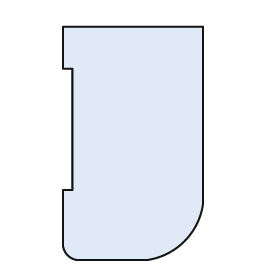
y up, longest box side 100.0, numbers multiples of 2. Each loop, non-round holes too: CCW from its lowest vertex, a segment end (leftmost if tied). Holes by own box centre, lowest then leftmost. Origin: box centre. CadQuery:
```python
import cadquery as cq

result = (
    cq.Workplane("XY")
    .moveTo(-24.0, -50.0)
    .lineTo(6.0, -50.0)
    .threePointArc((22.0, -42.0), (30.0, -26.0))
    .lineTo(30.0, 50.0)
    .lineTo(-30.0, 50.0)
    .lineTo(-30.0, 32.0)
    .lineTo(-26.0, 32.0)
    .lineTo(-26.0, -20.0)
    .lineTo(-30.0, -20.0)
    .lineTo(-30.0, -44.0)
    .threePointArc((-28.0, -48.0), (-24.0, -50.0))
    .close()
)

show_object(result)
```